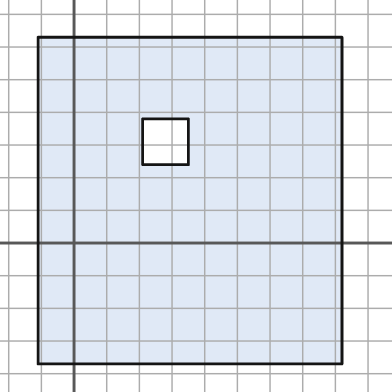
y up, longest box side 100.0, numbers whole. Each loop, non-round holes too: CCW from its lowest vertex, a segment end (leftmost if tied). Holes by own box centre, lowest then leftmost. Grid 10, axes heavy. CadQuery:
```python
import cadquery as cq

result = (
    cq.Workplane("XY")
    .moveTo(-11.0, -37.0)
    .lineTo(82.0, -37.0)
    .lineTo(82.0, 63.0)
    .lineTo(-11.0, 63.0)
    .close()
    .moveTo(21.0, 24.0)
    .lineTo(35.0, 24.0)
    .lineTo(35.0, 38.0)
    .lineTo(21.0, 38.0)
    .close()
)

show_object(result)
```